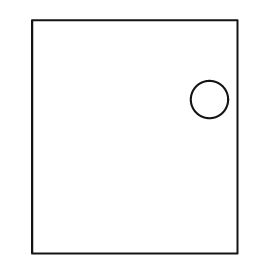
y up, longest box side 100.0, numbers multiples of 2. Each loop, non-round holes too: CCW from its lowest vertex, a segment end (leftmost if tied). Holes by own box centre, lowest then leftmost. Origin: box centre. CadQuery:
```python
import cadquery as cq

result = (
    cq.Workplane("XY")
    .moveTo(-44.0, -50.0)
    .lineTo(44.0, -50.0)
    .lineTo(44.0, 50.0)
    .lineTo(-44.0, 50.0)
    .close()
    .moveTo(32.0, 16.0)
    .circle(8.0)
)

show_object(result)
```